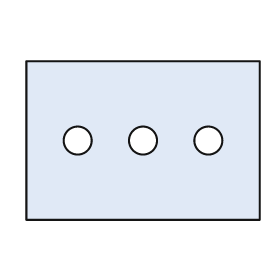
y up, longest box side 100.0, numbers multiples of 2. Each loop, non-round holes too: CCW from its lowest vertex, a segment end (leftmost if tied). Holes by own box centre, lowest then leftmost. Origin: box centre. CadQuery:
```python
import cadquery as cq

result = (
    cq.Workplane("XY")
    .moveTo(-50.0, -34.0)
    .lineTo(50.0, -34.0)
    .lineTo(50.0, 34.0)
    .lineTo(-50.0, 34.0)
    .close()
    .moveTo(-28.0, 0.0)
    .circle(6.0)
    .moveTo(0.0, 0.0)
    .circle(6.0)
    .moveTo(28.0, 0.0)
    .circle(6.0)
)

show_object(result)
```